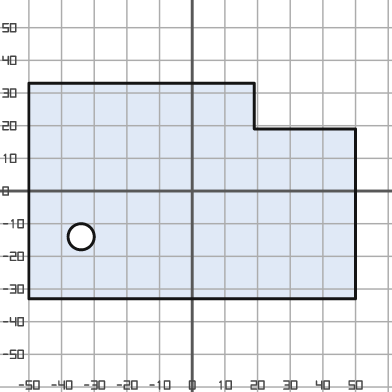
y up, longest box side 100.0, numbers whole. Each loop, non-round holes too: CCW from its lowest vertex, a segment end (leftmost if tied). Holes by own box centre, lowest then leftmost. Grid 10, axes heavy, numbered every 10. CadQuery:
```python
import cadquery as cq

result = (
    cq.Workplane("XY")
    .moveTo(-50.0, -33.0)
    .lineTo(50.0, -33.0)
    .lineTo(50.0, 19.0)
    .lineTo(19.0, 19.0)
    .lineTo(19.0, 33.0)
    .lineTo(-50.0, 33.0)
    .close()
    .moveTo(-34.0, -14.0)
    .circle(4.0)
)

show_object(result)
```